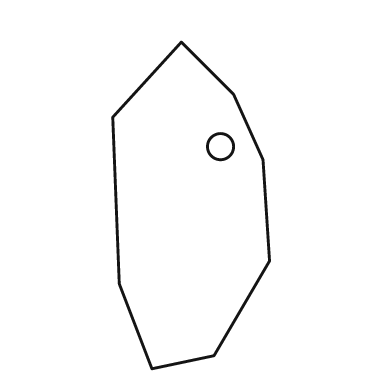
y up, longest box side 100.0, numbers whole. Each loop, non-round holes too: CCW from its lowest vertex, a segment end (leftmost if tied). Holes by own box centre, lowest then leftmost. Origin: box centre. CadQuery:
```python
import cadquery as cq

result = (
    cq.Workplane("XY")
    .moveTo(-12.0, -50.0)
    .lineTo(7.0, -46.0)
    .lineTo(24.0, -17.0)
    .lineTo(22.0, 14.0)
    .lineTo(13.0, 34.0)
    .lineTo(-3.0, 50.0)
    .lineTo(-24.0, 27.0)
    .lineTo(-22.0, -24.0)
    .close()
    .moveTo(9.0, 18.0)
    .circle(4.0)
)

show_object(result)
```